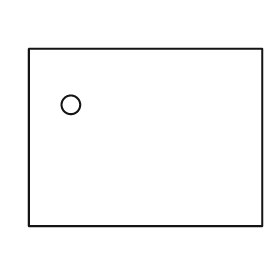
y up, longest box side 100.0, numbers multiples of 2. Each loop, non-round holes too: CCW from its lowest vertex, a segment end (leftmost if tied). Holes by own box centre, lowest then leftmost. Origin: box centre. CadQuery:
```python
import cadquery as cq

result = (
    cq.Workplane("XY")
    .moveTo(-50.0, -38.0)
    .lineTo(50.0, -38.0)
    .lineTo(50.0, 38.0)
    .lineTo(-50.0, 38.0)
    .close()
    .moveTo(-32.0, 14.0)
    .circle(4.0)
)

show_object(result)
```